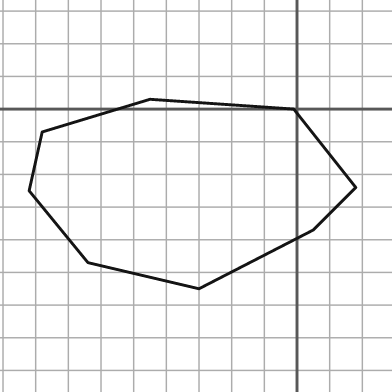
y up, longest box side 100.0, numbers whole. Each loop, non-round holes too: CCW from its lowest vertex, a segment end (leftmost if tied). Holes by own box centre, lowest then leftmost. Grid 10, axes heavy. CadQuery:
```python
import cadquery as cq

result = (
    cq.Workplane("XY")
    .moveTo(-30.0, -55.0)
    .lineTo(5.0, -37.0)
    .lineTo(18.0, -24.0)
    .lineTo(-1.0, 0.0)
    .lineTo(-45.0, 3.0)
    .lineTo(-78.0, -7.0)
    .lineTo(-82.0, -25.0)
    .lineTo(-64.0, -47.0)
    .close()
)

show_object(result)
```